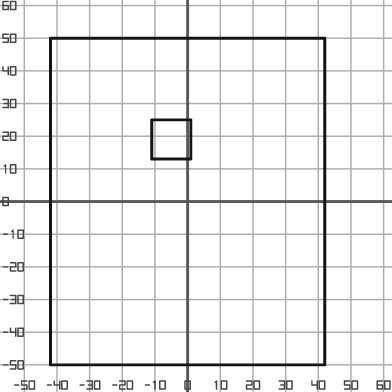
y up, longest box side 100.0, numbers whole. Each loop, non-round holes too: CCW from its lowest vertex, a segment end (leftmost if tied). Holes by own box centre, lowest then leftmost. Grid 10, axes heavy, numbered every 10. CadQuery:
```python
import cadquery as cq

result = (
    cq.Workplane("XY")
    .moveTo(-42.0, -50.0)
    .lineTo(42.0, -50.0)
    .lineTo(42.0, 50.0)
    .lineTo(-42.0, 50.0)
    .close()
    .moveTo(-11.0, 13.0)
    .lineTo(1.0, 13.0)
    .lineTo(1.0, 25.0)
    .lineTo(-11.0, 25.0)
    .close()
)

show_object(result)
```